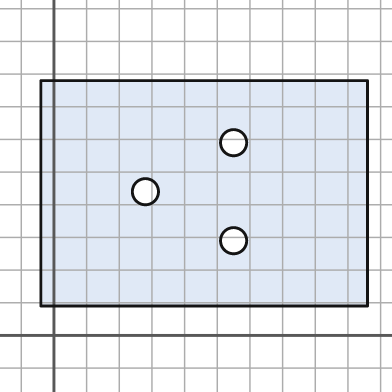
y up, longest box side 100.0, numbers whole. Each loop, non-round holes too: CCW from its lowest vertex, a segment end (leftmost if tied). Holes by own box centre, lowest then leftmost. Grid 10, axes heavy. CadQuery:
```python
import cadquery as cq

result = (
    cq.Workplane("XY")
    .moveTo(-4.0, 9.0)
    .lineTo(96.0, 9.0)
    .lineTo(96.0, 78.0)
    .lineTo(-4.0, 78.0)
    .close()
    .moveTo(55.0, 29.0)
    .circle(4.0)
    .moveTo(28.0, 44.0)
    .circle(4.0)
    .moveTo(55.0, 59.0)
    .circle(4.0)
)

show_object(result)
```